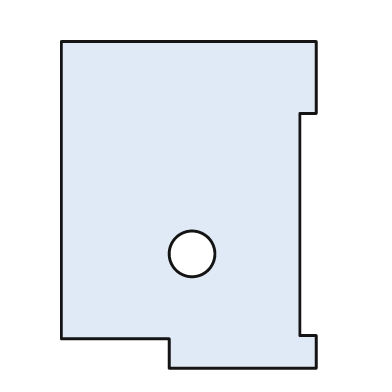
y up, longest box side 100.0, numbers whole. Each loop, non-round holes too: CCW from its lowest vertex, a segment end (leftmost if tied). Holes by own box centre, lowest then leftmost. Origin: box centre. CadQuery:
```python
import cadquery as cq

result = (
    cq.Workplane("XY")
    .moveTo(-6.0, -50.0)
    .lineTo(39.0, -50.0)
    .lineTo(39.0, -40.0)
    .lineTo(34.0, -40.0)
    .lineTo(34.0, 28.0)
    .lineTo(39.0, 28.0)
    .lineTo(39.0, 50.0)
    .lineTo(-39.0, 50.0)
    .lineTo(-39.0, -41.0)
    .lineTo(-6.0, -41.0)
    .close()
    .moveTo(1.0, -15.0)
    .circle(7.0)
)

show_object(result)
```